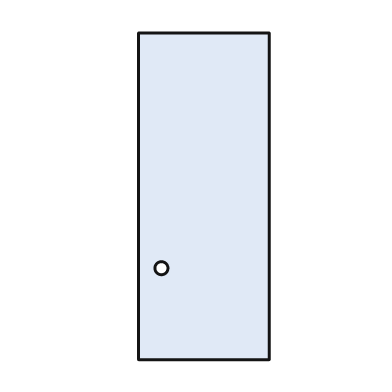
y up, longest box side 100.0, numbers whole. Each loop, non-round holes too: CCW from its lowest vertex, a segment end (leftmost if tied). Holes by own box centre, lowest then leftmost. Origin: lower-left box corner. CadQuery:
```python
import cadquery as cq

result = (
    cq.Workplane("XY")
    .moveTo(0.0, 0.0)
    .lineTo(40.0, 0.0)
    .lineTo(40.0, 100.0)
    .lineTo(0.0, 100.0)
    .close()
    .moveTo(7.0, 28.0)
    .circle(2.0)
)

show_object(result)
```